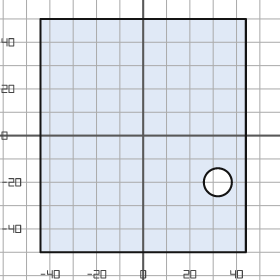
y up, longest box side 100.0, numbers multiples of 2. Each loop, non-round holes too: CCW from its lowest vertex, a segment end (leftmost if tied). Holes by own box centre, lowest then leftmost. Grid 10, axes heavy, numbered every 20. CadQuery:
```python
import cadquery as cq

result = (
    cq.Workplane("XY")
    .moveTo(-44.0, -50.0)
    .lineTo(44.0, -50.0)
    .lineTo(44.0, 50.0)
    .lineTo(-44.0, 50.0)
    .close()
    .moveTo(32.0, -20.0)
    .circle(6.0)
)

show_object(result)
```